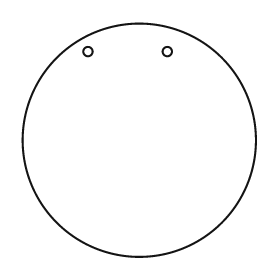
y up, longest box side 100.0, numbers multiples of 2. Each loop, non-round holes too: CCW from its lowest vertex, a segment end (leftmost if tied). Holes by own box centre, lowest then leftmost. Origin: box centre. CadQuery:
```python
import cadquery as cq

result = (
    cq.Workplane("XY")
    .moveTo(0.0, 0.0)
    .circle(50.0)
    .moveTo(-22.0, 38.0)
    .circle(2.0)
    .moveTo(12.0, 38.0)
    .circle(2.0)
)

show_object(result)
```